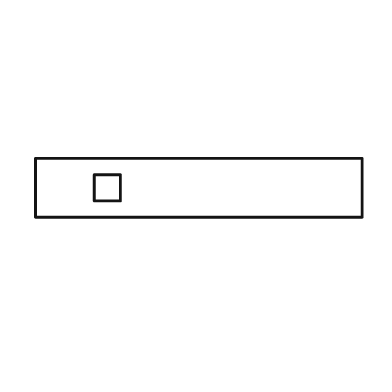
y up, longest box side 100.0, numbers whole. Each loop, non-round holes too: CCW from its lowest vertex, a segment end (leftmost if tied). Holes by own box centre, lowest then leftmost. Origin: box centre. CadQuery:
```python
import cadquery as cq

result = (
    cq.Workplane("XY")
    .moveTo(-50.0, -9.0)
    .lineTo(50.0, -9.0)
    .lineTo(50.0, 9.0)
    .lineTo(-50.0, 9.0)
    .close()
    .moveTo(-32.0, -4.0)
    .lineTo(-24.0, -4.0)
    .lineTo(-24.0, 4.0)
    .lineTo(-32.0, 4.0)
    .close()
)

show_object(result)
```